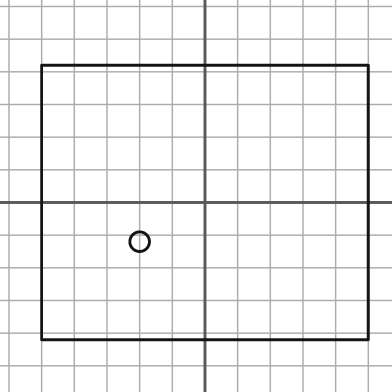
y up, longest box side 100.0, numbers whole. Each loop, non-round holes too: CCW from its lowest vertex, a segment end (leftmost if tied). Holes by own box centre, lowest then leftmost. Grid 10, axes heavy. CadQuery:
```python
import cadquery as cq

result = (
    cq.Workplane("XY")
    .moveTo(-50.0, -42.0)
    .lineTo(50.0, -42.0)
    .lineTo(50.0, 42.0)
    .lineTo(-50.0, 42.0)
    .close()
    .moveTo(-20.0, -12.0)
    .circle(3.0)
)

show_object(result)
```